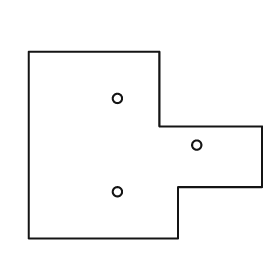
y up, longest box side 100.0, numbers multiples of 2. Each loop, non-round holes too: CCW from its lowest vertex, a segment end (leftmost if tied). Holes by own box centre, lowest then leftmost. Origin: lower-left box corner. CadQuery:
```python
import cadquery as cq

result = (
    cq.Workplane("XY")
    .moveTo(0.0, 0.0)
    .lineTo(64.0, 0.0)
    .lineTo(64.0, 22.0)
    .lineTo(100.0, 22.0)
    .lineTo(100.0, 48.0)
    .lineTo(56.0, 48.0)
    .lineTo(56.0, 80.0)
    .lineTo(0.0, 80.0)
    .close()
    .moveTo(38.0, 20.0)
    .circle(2.0)
    .moveTo(72.0, 40.0)
    .circle(2.0)
    .moveTo(38.0, 60.0)
    .circle(2.0)
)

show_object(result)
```